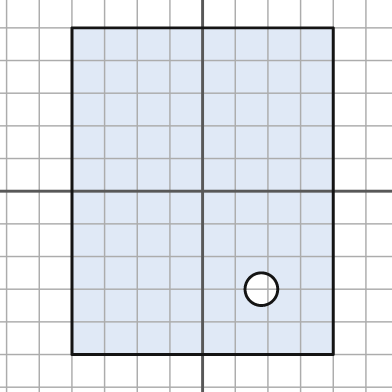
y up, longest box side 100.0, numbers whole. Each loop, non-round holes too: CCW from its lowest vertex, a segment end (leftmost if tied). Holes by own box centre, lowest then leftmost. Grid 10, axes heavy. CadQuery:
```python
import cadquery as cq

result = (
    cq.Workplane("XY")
    .moveTo(-40.0, -50.0)
    .lineTo(40.0, -50.0)
    .lineTo(40.0, 50.0)
    .lineTo(-40.0, 50.0)
    .close()
    .moveTo(18.0, -30.0)
    .circle(5.0)
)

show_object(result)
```